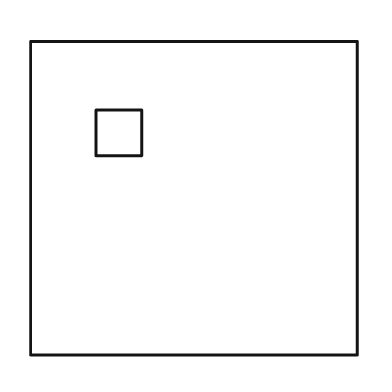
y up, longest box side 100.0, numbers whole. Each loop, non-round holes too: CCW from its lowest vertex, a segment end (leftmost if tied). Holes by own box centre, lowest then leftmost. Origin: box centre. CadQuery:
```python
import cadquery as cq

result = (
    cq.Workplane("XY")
    .moveTo(-50.0, -48.0)
    .lineTo(50.0, -48.0)
    .lineTo(50.0, 48.0)
    .lineTo(-50.0, 48.0)
    .close()
    .moveTo(-30.0, 13.0)
    .lineTo(-16.0, 13.0)
    .lineTo(-16.0, 27.0)
    .lineTo(-30.0, 27.0)
    .close()
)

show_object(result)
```